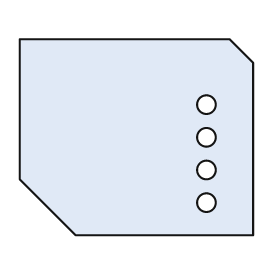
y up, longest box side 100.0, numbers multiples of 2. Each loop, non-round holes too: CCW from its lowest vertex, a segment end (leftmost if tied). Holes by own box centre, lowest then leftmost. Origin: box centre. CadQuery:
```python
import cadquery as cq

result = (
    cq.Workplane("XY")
    .moveTo(-26.0, -42.0)
    .lineTo(50.0, -42.0)
    .lineTo(50.0, 32.0)
    .lineTo(40.0, 42.0)
    .lineTo(-50.0, 42.0)
    .lineTo(-50.0, -18.0)
    .close()
    .moveTo(30.0, -28.0)
    .circle(4.0)
    .moveTo(30.0, -14.0)
    .circle(4.0)
    .moveTo(30.0, 0.0)
    .circle(4.0)
    .moveTo(30.0, 14.0)
    .circle(4.0)
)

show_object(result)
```